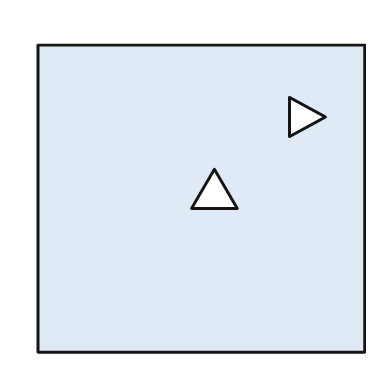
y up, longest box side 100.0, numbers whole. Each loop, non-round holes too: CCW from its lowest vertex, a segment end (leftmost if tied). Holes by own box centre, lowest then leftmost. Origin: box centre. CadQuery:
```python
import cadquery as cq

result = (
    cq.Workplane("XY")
    .moveTo(-50.0, -47.0)
    .lineTo(50.0, -47.0)
    .lineTo(50.0, 47.0)
    .lineTo(-50.0, 47.0)
    .close()
    .moveTo(-3.0, -3.0)
    .lineTo(11.0, -3.0)
    .lineTo(4.0, 9.0)
    .close()
    .moveTo(27.0, 19.0)
    .lineTo(38.0, 25.0)
    .lineTo(27.0, 31.0)
    .close()
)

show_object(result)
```